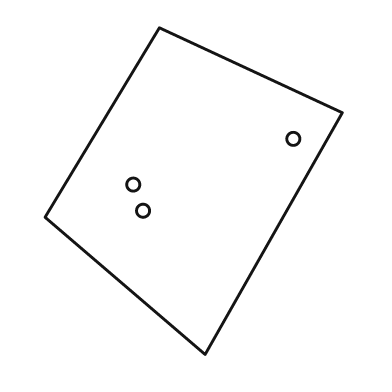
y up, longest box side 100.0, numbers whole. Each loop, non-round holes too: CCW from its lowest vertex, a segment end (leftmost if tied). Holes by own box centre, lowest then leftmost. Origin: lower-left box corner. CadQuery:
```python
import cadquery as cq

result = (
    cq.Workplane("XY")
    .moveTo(49.0, 0.0)
    .lineTo(91.0, 74.0)
    .lineTo(35.0, 100.0)
    .lineTo(0.0, 42.0)
    .close()
    .moveTo(30.0, 44.0)
    .circle(2.0)
    .moveTo(27.0, 52.0)
    .circle(2.0)
    .moveTo(76.0, 66.0)
    .circle(2.0)
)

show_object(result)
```